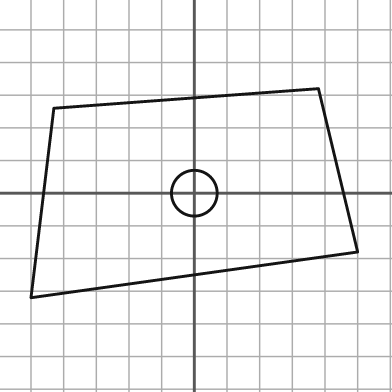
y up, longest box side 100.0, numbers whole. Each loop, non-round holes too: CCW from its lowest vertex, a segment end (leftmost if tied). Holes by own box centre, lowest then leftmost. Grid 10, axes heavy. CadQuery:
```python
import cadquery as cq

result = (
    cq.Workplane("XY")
    .moveTo(-50.0, -32.0)
    .lineTo(50.0, -18.0)
    .lineTo(38.0, 32.0)
    .lineTo(-43.0, 26.0)
    .close()
    .moveTo(0.0, 0.0)
    .circle(7.0)
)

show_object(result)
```